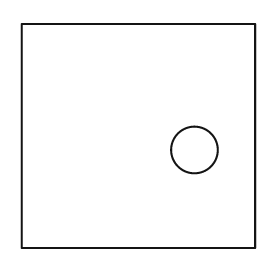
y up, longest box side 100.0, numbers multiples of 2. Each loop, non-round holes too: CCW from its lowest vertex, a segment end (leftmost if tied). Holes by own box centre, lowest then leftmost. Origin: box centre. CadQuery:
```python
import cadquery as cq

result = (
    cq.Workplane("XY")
    .moveTo(-50.0, -48.0)
    .lineTo(50.0, -48.0)
    .lineTo(50.0, 48.0)
    .lineTo(-50.0, 48.0)
    .close()
    .moveTo(24.0, -6.0)
    .circle(10.0)
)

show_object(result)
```